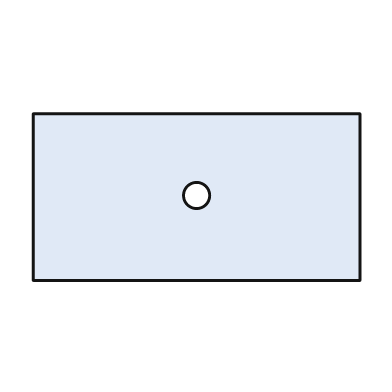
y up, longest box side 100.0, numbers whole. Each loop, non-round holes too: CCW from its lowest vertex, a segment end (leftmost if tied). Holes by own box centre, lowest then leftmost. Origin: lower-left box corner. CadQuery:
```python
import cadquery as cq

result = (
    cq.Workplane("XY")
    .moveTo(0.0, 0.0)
    .lineTo(100.0, 0.0)
    .lineTo(100.0, 51.0)
    .lineTo(0.0, 51.0)
    .close()
    .moveTo(50.0, 26.0)
    .circle(4.0)
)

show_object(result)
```